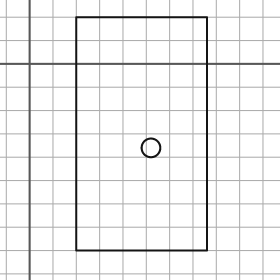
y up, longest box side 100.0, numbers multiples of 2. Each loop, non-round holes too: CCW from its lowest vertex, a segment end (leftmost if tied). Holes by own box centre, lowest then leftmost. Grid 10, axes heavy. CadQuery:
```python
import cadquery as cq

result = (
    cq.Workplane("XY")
    .moveTo(20.0, -80.0)
    .lineTo(76.0, -80.0)
    .lineTo(76.0, 20.0)
    .lineTo(20.0, 20.0)
    .close()
    .moveTo(52.0, -36.0)
    .circle(4.0)
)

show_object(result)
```